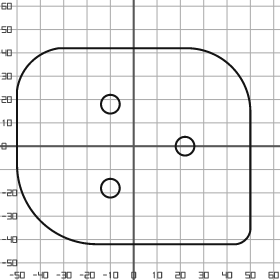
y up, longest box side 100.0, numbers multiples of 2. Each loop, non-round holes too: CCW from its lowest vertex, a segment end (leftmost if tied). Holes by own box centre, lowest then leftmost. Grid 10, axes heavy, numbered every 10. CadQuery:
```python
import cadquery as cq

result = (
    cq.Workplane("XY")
    .moveTo(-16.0, -42.0)
    .lineTo(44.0, -42.0)
    .threePointArc((48.0, -40.0), (50.0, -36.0))
    .lineTo(50.0, 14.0)
    .threePointArc((42.0, 34.0), (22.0, 42.0))
    .lineTo(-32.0, 42.0)
    .threePointArc((-44.0, 36.0), (-50.0, 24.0))
    .lineTo(-50.0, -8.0)
    .threePointArc((-40.0, -32.0), (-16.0, -42.0))
    .close()
    .moveTo(-10.0, -18.0)
    .circle(4.0)
    .moveTo(22.0, 0.0)
    .circle(4.0)
    .moveTo(-10.0, 18.0)
    .circle(4.0)
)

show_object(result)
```